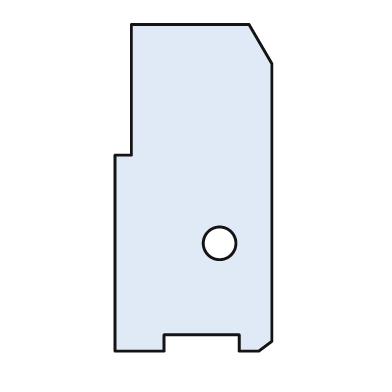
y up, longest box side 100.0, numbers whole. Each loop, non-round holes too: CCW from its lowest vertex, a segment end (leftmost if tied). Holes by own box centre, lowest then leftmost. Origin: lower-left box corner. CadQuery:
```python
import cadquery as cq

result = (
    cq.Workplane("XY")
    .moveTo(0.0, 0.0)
    .lineTo(15.0, 0.0)
    .lineTo(15.0, 5.0)
    .lineTo(38.0, 5.0)
    .lineTo(38.0, 0.0)
    .lineTo(44.0, 0.0)
    .lineTo(48.0, 3.0)
    .lineTo(48.0, 88.0)
    .lineTo(41.0, 100.0)
    .lineTo(5.0, 100.0)
    .lineTo(5.0, 60.0)
    .lineTo(0.0, 60.0)
    .close()
    .moveTo(32.0, 33.0)
    .circle(5.0)
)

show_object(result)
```